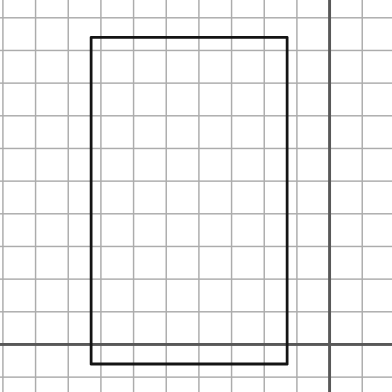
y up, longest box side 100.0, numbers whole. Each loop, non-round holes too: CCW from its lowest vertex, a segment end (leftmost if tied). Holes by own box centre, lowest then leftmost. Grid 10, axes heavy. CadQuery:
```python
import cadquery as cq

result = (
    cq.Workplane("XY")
    .moveTo(-73.0, -6.0)
    .lineTo(-13.0, -6.0)
    .lineTo(-13.0, 94.0)
    .lineTo(-73.0, 94.0)
    .close()
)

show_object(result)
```